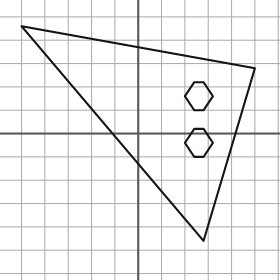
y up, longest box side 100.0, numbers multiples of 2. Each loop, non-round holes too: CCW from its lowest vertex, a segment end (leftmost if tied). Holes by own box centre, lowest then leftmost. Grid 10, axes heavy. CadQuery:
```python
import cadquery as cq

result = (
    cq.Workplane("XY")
    .moveTo(28.0, -46.0)
    .lineTo(50.0, 28.0)
    .lineTo(-50.0, 46.0)
    .close()
    .moveTo(24.0, -10.0)
    .lineTo(28.0, -10.0)
    .lineTo(32.0, -4.0)
    .lineTo(28.0, 2.0)
    .lineTo(24.0, 2.0)
    .lineTo(20.0, -4.0)
    .close()
    .moveTo(24.0, 10.0)
    .lineTo(28.0, 10.0)
    .lineTo(32.0, 16.0)
    .lineTo(28.0, 22.0)
    .lineTo(24.0, 22.0)
    .lineTo(20.0, 16.0)
    .close()
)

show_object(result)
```